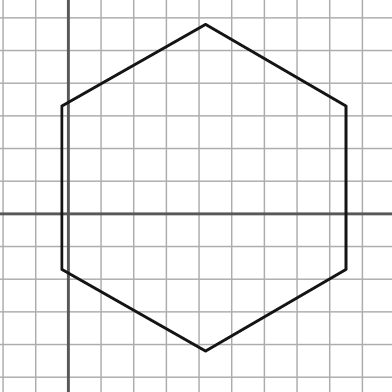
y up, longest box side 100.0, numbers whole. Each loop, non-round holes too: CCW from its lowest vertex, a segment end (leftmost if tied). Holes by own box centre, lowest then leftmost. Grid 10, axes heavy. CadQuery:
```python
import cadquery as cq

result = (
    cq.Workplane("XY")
    .moveTo(42.0, -42.0)
    .lineTo(85.0, -17.0)
    .lineTo(85.0, 33.0)
    .lineTo(42.0, 58.0)
    .lineTo(-2.0, 33.0)
    .lineTo(-2.0, -17.0)
    .close()
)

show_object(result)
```